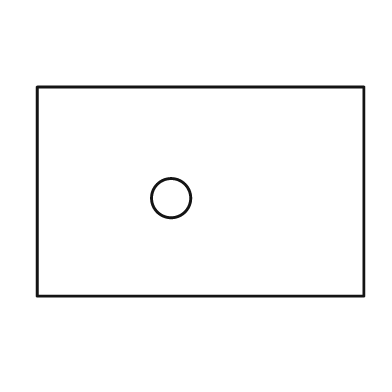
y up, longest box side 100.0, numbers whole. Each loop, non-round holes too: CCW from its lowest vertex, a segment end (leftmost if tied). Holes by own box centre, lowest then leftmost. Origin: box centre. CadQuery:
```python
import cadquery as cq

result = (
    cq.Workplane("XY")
    .moveTo(-50.0, -32.0)
    .lineTo(50.0, -32.0)
    .lineTo(50.0, 32.0)
    .lineTo(-50.0, 32.0)
    .close()
    .moveTo(-9.0, -2.0)
    .circle(6.0)
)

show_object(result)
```